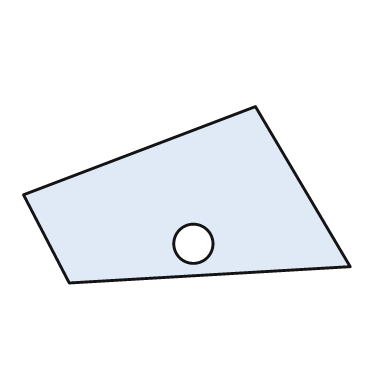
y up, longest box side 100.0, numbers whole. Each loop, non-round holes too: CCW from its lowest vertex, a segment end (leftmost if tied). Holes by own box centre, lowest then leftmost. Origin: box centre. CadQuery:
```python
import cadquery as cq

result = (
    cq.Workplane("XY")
    .moveTo(-36.0, -27.0)
    .lineTo(50.0, -22.0)
    .lineTo(21.0, 27.0)
    .lineTo(-50.0, 0.0)
    .close()
    .moveTo(2.0, -15.0)
    .circle(6.0)
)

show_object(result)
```